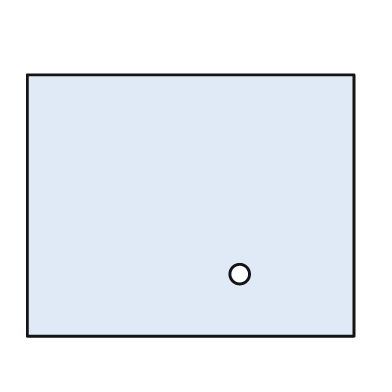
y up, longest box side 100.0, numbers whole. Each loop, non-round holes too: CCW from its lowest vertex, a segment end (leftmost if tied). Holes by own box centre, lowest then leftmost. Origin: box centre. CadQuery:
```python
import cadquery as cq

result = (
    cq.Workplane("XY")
    .moveTo(-50.0, -40.0)
    .lineTo(50.0, -40.0)
    .lineTo(50.0, 40.0)
    .lineTo(-50.0, 40.0)
    .close()
    .moveTo(15.0, -21.0)
    .circle(3.0)
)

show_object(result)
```